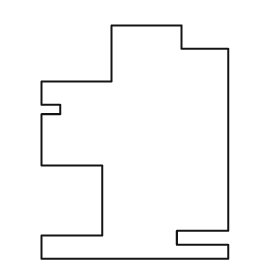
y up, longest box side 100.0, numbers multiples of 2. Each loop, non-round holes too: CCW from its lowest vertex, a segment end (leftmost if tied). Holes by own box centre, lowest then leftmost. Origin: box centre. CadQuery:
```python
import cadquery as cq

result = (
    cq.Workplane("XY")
    .moveTo(-40.0, -50.0)
    .lineTo(40.0, -50.0)
    .lineTo(40.0, -44.0)
    .lineTo(18.0, -44.0)
    .lineTo(18.0, -38.0)
    .lineTo(40.0, -38.0)
    .lineTo(40.0, 40.0)
    .lineTo(20.0, 40.0)
    .lineTo(20.0, 50.0)
    .lineTo(-10.0, 50.0)
    .lineTo(-10.0, 26.0)
    .lineTo(-40.0, 26.0)
    .lineTo(-40.0, 16.0)
    .lineTo(-32.0, 16.0)
    .lineTo(-32.0, 12.0)
    .lineTo(-40.0, 12.0)
    .lineTo(-40.0, -10.0)
    .lineTo(-14.0, -10.0)
    .lineTo(-14.0, -40.0)
    .lineTo(-40.0, -40.0)
    .close()
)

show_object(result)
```